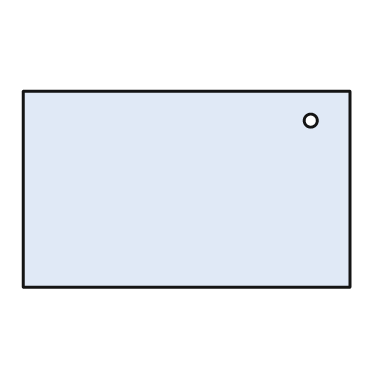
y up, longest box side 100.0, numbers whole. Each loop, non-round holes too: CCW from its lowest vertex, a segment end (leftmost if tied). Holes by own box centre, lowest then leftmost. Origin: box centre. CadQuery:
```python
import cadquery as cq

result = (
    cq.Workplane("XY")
    .moveTo(-50.0, -30.0)
    .lineTo(50.0, -30.0)
    .lineTo(50.0, 30.0)
    .lineTo(-50.0, 30.0)
    .close()
    .moveTo(38.0, 21.0)
    .circle(2.0)
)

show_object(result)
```